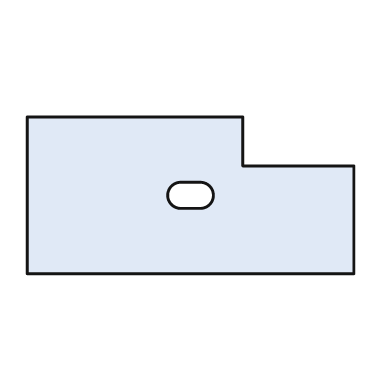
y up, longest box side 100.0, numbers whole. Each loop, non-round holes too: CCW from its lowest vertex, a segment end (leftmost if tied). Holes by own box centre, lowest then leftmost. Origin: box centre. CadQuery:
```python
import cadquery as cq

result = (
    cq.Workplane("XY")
    .moveTo(-50.0, -24.0)
    .lineTo(50.0, -24.0)
    .lineTo(50.0, 9.0)
    .lineTo(16.0, 9.0)
    .lineTo(16.0, 24.0)
    .lineTo(-50.0, 24.0)
    .close()
    .moveTo(-3.0, -4.0)
    .lineTo(3.0, -4.0)
    .threePointArc((7.0, 0.0), (3.0, 4.0))
    .lineTo(-3.0, 4.0)
    .threePointArc((-7.0, 0.0), (-3.0, -4.0))
    .close()
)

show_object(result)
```